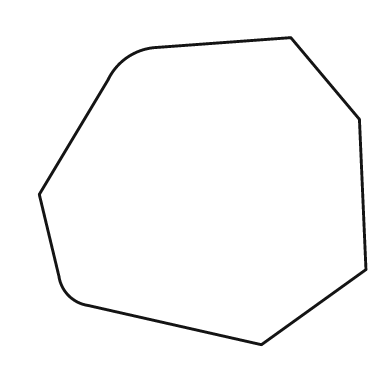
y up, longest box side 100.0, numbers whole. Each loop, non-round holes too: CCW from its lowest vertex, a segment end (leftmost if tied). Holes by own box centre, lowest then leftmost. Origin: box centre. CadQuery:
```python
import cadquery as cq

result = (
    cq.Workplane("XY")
    .moveTo(18.0, -47.0)
    .lineTo(50.0, -24.0)
    .lineTo(48.0, 22.0)
    .lineTo(27.0, 47.0)
    .lineTo(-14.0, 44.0)
    .threePointArc((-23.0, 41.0), (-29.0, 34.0))
    .lineTo(-50.0, -1.0)
    .lineTo(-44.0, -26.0)
    .threePointArc((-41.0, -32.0), (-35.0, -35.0))
    .close()
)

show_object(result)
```